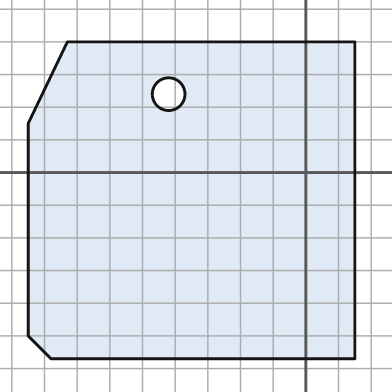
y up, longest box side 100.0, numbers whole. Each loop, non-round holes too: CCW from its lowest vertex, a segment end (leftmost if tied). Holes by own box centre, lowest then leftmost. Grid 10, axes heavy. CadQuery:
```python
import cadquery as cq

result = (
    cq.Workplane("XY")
    .moveTo(-78.0, -57.0)
    .lineTo(15.0, -57.0)
    .lineTo(15.0, 40.0)
    .lineTo(-73.0, 40.0)
    .lineTo(-85.0, 15.0)
    .lineTo(-85.0, -50.0)
    .close()
    .moveTo(-42.0, 24.0)
    .circle(5.0)
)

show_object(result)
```